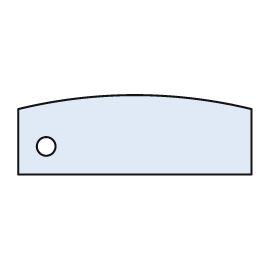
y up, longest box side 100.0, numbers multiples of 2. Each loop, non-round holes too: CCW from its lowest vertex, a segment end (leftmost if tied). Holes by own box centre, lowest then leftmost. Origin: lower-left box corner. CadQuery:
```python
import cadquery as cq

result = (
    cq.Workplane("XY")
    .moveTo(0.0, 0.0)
    .lineTo(100.0, 0.0)
    .lineTo(100.0, 28.0)
    .threePointArc((50.0, 34.0), (0.0, 28.0))
    .close()
    .moveTo(12.0, 12.0)
    .circle(4.0)
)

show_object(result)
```